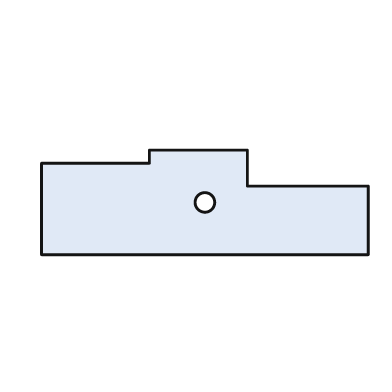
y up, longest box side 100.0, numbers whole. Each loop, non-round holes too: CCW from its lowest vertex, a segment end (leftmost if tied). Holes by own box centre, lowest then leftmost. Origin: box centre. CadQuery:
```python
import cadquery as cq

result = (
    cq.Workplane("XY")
    .moveTo(-50.0, -16.0)
    .lineTo(50.0, -16.0)
    .lineTo(50.0, 5.0)
    .lineTo(13.0, 5.0)
    .lineTo(13.0, 16.0)
    .lineTo(-17.0, 16.0)
    .lineTo(-17.0, 12.0)
    .lineTo(-50.0, 12.0)
    .close()
    .moveTo(0.0, 0.0)
    .circle(3.0)
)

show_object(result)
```